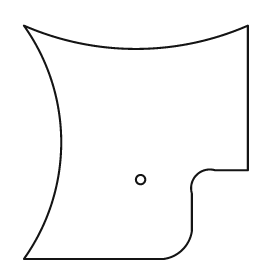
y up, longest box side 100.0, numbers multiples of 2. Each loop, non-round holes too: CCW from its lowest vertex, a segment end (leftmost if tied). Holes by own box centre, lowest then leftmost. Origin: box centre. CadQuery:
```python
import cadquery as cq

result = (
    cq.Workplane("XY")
    .moveTo(-48.0, -50.0)
    .lineTo(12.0, -50.0)
    .threePointArc((20.0, -46.0), (24.0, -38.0))
    .lineTo(24.0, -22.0)
    .threePointArc((26.0, -14.0), (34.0, -12.0))
    .lineTo(48.0, -12.0)
    .lineTo(48.0, 50.0)
    .threePointArc((0.0, 40.0), (-48.0, 50.0))
    .threePointArc((-32.0, 0.0), (-48.0, -50.0))
    .close()
    .moveTo(2.0, -16.0)
    .circle(2.0)
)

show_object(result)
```